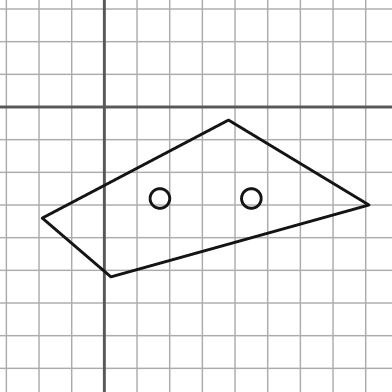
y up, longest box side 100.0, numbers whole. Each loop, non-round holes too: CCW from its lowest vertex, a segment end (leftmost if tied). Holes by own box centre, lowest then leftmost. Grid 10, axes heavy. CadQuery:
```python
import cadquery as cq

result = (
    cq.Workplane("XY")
    .moveTo(2.0, -52.0)
    .lineTo(81.0, -30.0)
    .lineTo(38.0, -4.0)
    .lineTo(-19.0, -34.0)
    .close()
    .moveTo(17.0, -28.0)
    .circle(3.0)
    .moveTo(45.0, -28.0)
    .circle(3.0)
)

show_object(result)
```